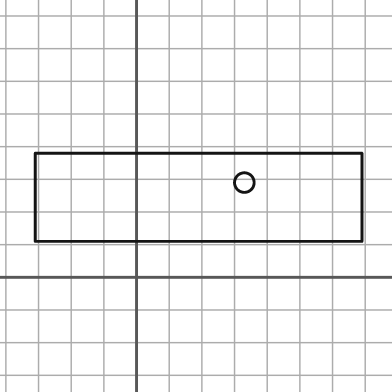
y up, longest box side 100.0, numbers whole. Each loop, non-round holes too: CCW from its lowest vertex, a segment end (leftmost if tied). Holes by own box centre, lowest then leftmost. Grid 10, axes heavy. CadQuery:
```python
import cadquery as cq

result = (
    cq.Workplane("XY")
    .moveTo(-31.0, 11.0)
    .lineTo(69.0, 11.0)
    .lineTo(69.0, 38.0)
    .lineTo(-31.0, 38.0)
    .close()
    .moveTo(33.0, 29.0)
    .circle(3.0)
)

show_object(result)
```